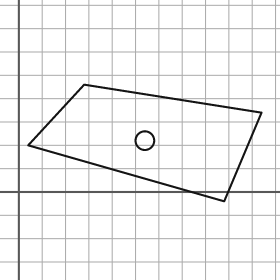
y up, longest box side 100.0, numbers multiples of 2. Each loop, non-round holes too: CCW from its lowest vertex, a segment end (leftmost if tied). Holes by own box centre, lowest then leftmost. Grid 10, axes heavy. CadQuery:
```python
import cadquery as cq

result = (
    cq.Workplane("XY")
    .moveTo(88.0, -4.0)
    .lineTo(104.0, 34.0)
    .lineTo(28.0, 46.0)
    .lineTo(4.0, 20.0)
    .close()
    .moveTo(54.0, 22.0)
    .circle(4.0)
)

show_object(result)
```